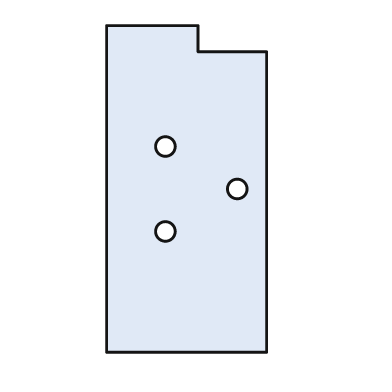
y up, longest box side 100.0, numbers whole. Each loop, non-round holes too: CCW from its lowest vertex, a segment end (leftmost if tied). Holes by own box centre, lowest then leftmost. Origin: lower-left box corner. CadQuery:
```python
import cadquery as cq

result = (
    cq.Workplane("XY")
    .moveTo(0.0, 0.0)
    .lineTo(49.0, 0.0)
    .lineTo(49.0, 92.0)
    .lineTo(28.0, 92.0)
    .lineTo(28.0, 100.0)
    .lineTo(0.0, 100.0)
    .close()
    .moveTo(18.0, 37.0)
    .circle(3.0)
    .moveTo(40.0, 50.0)
    .circle(3.0)
    .moveTo(18.0, 63.0)
    .circle(3.0)
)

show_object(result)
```